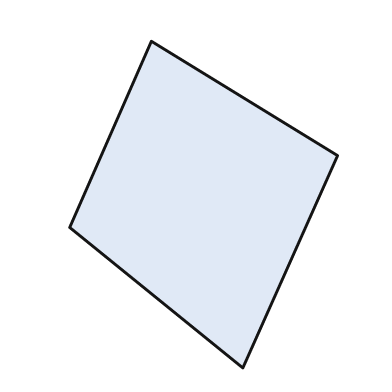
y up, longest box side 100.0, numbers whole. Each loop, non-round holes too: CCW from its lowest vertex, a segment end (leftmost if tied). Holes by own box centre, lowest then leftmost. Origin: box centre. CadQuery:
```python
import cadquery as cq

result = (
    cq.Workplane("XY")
    .moveTo(12.0, -50.0)
    .lineTo(41.0, 15.0)
    .lineTo(-16.0, 50.0)
    .lineTo(-41.0, -7.0)
    .close()
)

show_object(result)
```